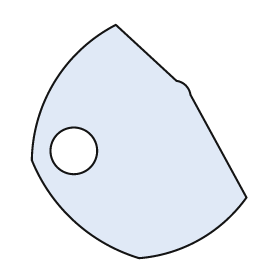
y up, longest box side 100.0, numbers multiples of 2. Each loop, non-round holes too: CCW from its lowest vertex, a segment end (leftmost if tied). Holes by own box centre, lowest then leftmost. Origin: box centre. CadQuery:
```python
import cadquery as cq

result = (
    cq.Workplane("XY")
    .moveTo(0.0, -50.0)
    .threePointArc((26.0, -42.0), (46.0, -24.0))
    .lineTo(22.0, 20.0)
    .threePointArc((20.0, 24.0), (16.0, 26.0))
    .lineTo(-10.0, 50.0)
    .threePointArc((-36.0, 26.0), (-46.0, -8.0))
    .threePointArc((-28.0, -34.0), (0.0, -50.0))
    .close()
    .moveTo(-28.0, -4.0)
    .circle(10.0)
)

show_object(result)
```